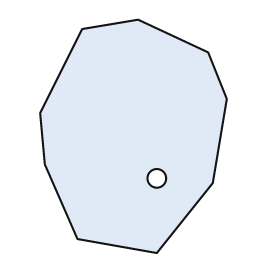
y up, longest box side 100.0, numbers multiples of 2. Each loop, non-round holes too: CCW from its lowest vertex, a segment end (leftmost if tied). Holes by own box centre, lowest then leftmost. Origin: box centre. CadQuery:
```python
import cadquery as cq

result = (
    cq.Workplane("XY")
    .moveTo(10.0, -50.0)
    .lineTo(34.0, -20.0)
    .lineTo(40.0, 16.0)
    .lineTo(32.0, 36.0)
    .lineTo(2.0, 50.0)
    .lineTo(-22.0, 46.0)
    .lineTo(-40.0, 10.0)
    .lineTo(-38.0, -12.0)
    .lineTo(-24.0, -44.0)
    .close()
    .moveTo(10.0, -18.0)
    .circle(4.0)
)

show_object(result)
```